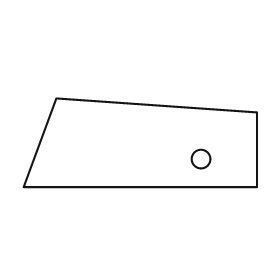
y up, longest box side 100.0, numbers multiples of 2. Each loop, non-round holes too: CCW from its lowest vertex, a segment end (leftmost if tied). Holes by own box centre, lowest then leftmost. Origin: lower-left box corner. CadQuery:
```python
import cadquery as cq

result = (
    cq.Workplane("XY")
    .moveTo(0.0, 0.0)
    .lineTo(100.0, 0.0)
    .lineTo(100.0, 32.0)
    .lineTo(14.0, 38.0)
    .close()
    .moveTo(76.0, 12.0)
    .circle(4.0)
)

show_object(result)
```